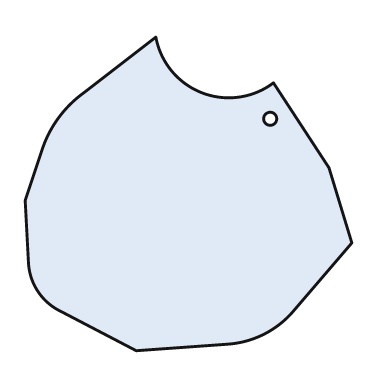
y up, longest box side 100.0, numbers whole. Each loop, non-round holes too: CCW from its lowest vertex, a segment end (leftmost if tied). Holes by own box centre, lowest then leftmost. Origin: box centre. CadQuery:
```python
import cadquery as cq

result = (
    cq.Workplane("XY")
    .moveTo(-16.0, -48.0)
    .lineTo(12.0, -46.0)
    .threePointArc((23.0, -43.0), (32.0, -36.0))
    .lineTo(50.0, -15.0)
    .lineTo(43.0, 8.0)
    .lineTo(26.0, 34.0)
    .threePointArc((4.0, 31.0), (-10.0, 48.0))
    .lineTo(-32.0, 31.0)
    .threePointArc((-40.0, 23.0), (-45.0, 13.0))
    .lineTo(-50.0, -2.0)
    .lineTo(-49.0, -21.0)
    .threePointArc((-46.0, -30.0), (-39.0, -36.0))
    .close()
    .moveTo(25.0, 23.0)
    .circle(2.0)
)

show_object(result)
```